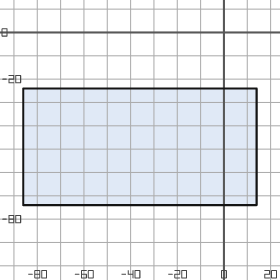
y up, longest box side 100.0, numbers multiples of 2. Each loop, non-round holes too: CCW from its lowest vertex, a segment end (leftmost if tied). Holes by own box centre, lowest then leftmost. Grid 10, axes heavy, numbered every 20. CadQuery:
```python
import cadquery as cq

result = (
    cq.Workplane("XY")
    .moveTo(-86.0, -74.0)
    .lineTo(14.0, -74.0)
    .lineTo(14.0, -24.0)
    .lineTo(-86.0, -24.0)
    .close()
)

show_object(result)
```